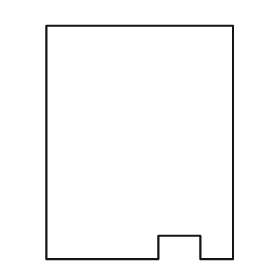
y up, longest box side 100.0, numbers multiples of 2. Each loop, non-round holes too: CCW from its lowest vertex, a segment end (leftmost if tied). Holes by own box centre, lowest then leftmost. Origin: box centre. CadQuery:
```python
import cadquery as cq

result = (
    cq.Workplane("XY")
    .moveTo(-40.0, -50.0)
    .lineTo(8.0, -50.0)
    .lineTo(8.0, -40.0)
    .lineTo(26.0, -40.0)
    .lineTo(26.0, -50.0)
    .lineTo(40.0, -50.0)
    .lineTo(40.0, 50.0)
    .lineTo(-40.0, 50.0)
    .close()
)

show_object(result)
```